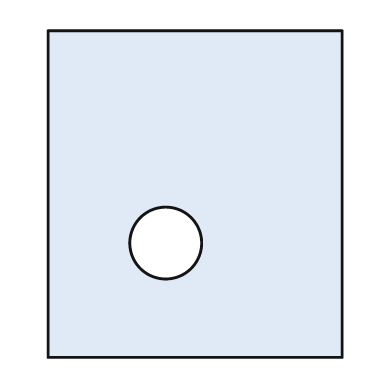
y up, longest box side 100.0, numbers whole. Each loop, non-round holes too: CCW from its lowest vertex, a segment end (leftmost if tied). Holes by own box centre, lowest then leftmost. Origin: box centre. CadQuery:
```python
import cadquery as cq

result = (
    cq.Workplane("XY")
    .moveTo(-45.0, -50.0)
    .lineTo(45.0, -50.0)
    .lineTo(45.0, 50.0)
    .lineTo(-45.0, 50.0)
    .close()
    .moveTo(-9.0, -15.0)
    .circle(11.0)
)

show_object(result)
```